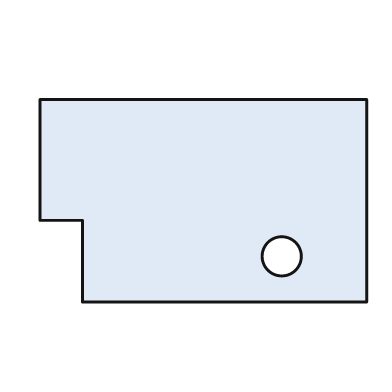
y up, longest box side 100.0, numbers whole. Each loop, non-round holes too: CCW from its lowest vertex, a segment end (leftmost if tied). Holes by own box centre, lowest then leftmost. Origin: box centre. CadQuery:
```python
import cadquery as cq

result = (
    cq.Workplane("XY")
    .moveTo(-37.0, -31.0)
    .lineTo(50.0, -31.0)
    .lineTo(50.0, 31.0)
    .lineTo(-50.0, 31.0)
    .lineTo(-50.0, -6.0)
    .lineTo(-37.0, -6.0)
    .close()
    .moveTo(24.0, -17.0)
    .circle(6.0)
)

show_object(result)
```